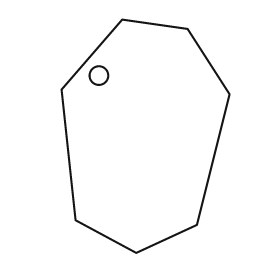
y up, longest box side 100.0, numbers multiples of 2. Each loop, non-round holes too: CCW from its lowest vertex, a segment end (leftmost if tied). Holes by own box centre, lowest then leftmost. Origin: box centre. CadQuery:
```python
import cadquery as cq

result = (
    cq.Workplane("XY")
    .moveTo(-4.0, -50.0)
    .lineTo(22.0, -38.0)
    .lineTo(36.0, 18.0)
    .lineTo(18.0, 46.0)
    .lineTo(-10.0, 50.0)
    .lineTo(-36.0, 20.0)
    .lineTo(-30.0, -36.0)
    .close()
    .moveTo(-20.0, 26.0)
    .circle(4.0)
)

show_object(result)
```